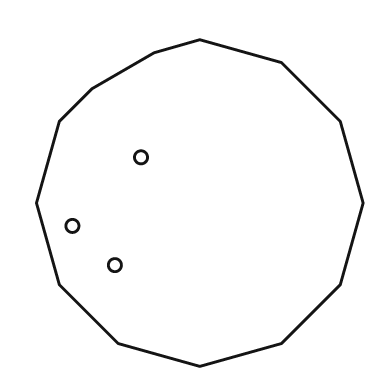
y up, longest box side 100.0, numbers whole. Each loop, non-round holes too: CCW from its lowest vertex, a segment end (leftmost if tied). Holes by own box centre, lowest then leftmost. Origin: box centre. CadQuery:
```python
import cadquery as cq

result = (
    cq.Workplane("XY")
    .moveTo(0.0, -50.0)
    .lineTo(25.0, -43.0)
    .lineTo(43.0, -25.0)
    .lineTo(50.0, 0.0)
    .lineTo(43.0, 25.0)
    .lineTo(25.0, 43.0)
    .lineTo(0.0, 50.0)
    .lineTo(-14.0, 46.0)
    .lineTo(-33.0, 35.0)
    .lineTo(-43.0, 25.0)
    .lineTo(-50.0, 0.0)
    .lineTo(-43.0, -25.0)
    .lineTo(-25.0, -43.0)
    .close()
    .moveTo(-26.0, -19.0)
    .circle(2.0)
    .moveTo(-39.0, -7.0)
    .circle(2.0)
    .moveTo(-18.0, 14.0)
    .circle(2.0)
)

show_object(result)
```